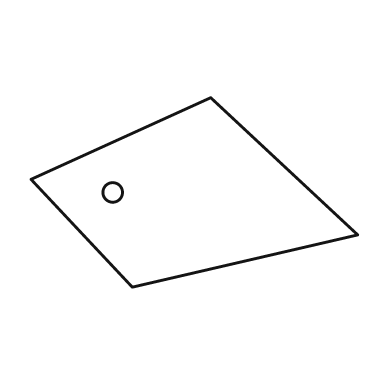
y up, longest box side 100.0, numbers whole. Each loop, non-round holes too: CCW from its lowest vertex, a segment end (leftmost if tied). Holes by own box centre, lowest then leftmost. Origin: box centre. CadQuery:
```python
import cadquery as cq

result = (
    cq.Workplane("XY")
    .moveTo(-19.0, -29.0)
    .lineTo(50.0, -13.0)
    .lineTo(5.0, 29.0)
    .lineTo(-50.0, 4.0)
    .close()
    .moveTo(-25.0, 0.0)
    .circle(3.0)
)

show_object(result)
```